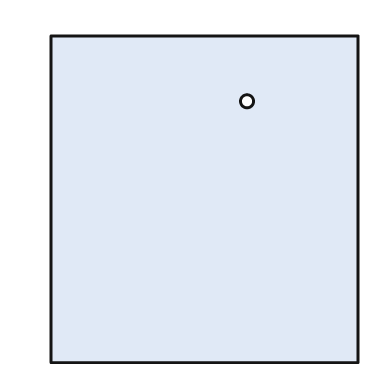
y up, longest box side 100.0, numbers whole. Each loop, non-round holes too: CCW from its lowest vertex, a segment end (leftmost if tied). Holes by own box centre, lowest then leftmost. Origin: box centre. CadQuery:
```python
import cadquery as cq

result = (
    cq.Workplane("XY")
    .moveTo(-47.0, -50.0)
    .lineTo(47.0, -50.0)
    .lineTo(47.0, 50.0)
    .lineTo(-47.0, 50.0)
    .close()
    .moveTo(13.0, 30.0)
    .circle(2.0)
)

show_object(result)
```